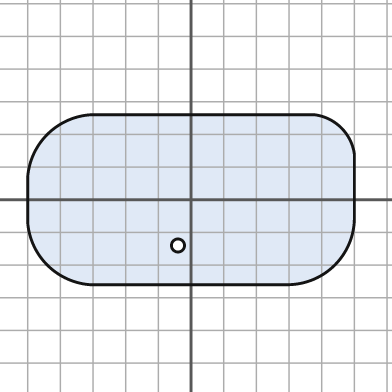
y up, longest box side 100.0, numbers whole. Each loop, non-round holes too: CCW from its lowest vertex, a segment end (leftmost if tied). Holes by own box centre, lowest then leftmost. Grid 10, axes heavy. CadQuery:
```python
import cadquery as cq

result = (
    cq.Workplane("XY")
    .moveTo(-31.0, -26.0)
    .lineTo(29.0, -26.0)
    .threePointArc((44.0, -20.0), (50.0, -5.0))
    .lineTo(50.0, 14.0)
    .threePointArc((46.0, 22.0), (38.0, 26.0))
    .lineTo(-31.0, 26.0)
    .threePointArc((-44.0, 20.0), (-50.0, 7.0))
    .lineTo(-50.0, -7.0)
    .threePointArc((-44.0, -20.0), (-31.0, -26.0))
    .close()
    .moveTo(-4.0, -14.0)
    .circle(2.0)
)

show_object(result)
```